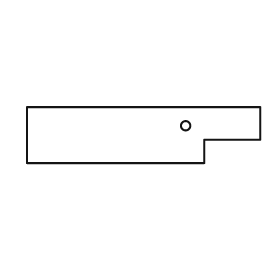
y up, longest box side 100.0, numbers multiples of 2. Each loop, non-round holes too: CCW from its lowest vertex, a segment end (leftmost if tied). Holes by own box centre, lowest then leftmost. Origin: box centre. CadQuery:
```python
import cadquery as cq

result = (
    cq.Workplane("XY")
    .moveTo(-50.0, -12.0)
    .lineTo(26.0, -12.0)
    .lineTo(26.0, -2.0)
    .lineTo(50.0, -2.0)
    .lineTo(50.0, 12.0)
    .lineTo(-50.0, 12.0)
    .close()
    .moveTo(18.0, 4.0)
    .circle(2.0)
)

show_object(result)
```